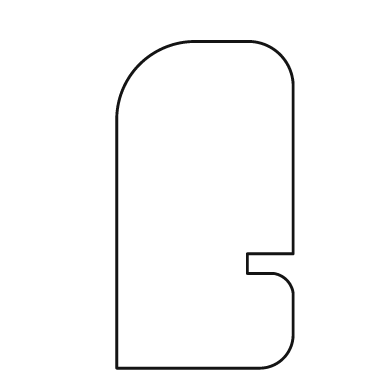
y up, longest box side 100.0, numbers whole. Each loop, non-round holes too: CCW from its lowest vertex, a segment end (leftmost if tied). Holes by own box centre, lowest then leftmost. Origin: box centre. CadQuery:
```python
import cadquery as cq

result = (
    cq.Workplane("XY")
    .moveTo(-27.0, -50.0)
    .lineTo(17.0, -50.0)
    .threePointArc((24.0, -47.0), (27.0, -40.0))
    .lineTo(27.0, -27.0)
    .threePointArc((25.0, -23.0), (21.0, -21.0))
    .lineTo(13.0, -21.0)
    .lineTo(13.0, -15.0)
    .lineTo(27.0, -15.0)
    .lineTo(27.0, 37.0)
    .threePointArc((23.0, 46.0), (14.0, 50.0))
    .lineTo(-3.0, 50.0)
    .threePointArc((-20.0, 43.0), (-27.0, 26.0))
    .close()
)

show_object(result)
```